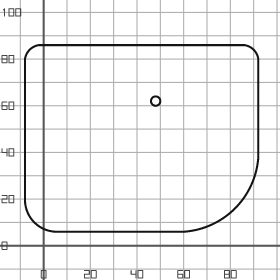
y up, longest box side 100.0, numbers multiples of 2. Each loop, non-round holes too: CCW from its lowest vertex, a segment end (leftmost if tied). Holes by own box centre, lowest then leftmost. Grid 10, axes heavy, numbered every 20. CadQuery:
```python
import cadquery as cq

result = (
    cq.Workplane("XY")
    .moveTo(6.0, 6.0)
    .lineTo(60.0, 6.0)
    .threePointArc((82.0, 16.0), (92.0, 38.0))
    .lineTo(92.0, 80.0)
    .threePointArc((90.0, 84.0), (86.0, 86.0))
    .lineTo(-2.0, 86.0)
    .threePointArc((-6.0, 84.0), (-8.0, 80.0))
    .lineTo(-8.0, 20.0)
    .threePointArc((-4.0, 10.0), (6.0, 6.0))
    .close()
    .moveTo(48.0, 62.0)
    .circle(2.0)
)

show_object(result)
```